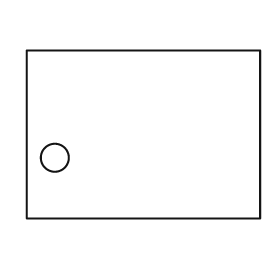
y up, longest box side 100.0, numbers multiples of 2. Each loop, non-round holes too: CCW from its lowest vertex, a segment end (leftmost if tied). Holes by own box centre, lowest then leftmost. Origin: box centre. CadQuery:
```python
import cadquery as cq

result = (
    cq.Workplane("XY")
    .moveTo(-50.0, -36.0)
    .lineTo(50.0, -36.0)
    .lineTo(50.0, 36.0)
    .lineTo(-50.0, 36.0)
    .close()
    .moveTo(-38.0, -10.0)
    .circle(6.0)
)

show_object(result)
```